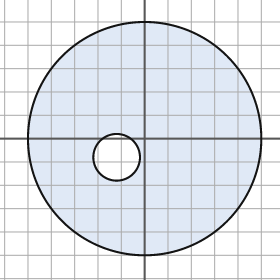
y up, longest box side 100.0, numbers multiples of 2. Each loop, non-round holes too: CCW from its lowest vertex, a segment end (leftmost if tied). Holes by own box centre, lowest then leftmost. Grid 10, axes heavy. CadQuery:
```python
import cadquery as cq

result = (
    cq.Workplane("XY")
    .moveTo(0.0, 0.0)
    .circle(50.0)
    .moveTo(-12.0, -8.0)
    .circle(10.0)
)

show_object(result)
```